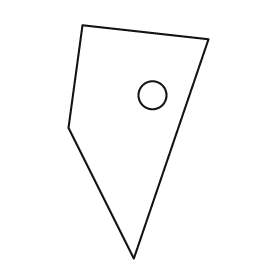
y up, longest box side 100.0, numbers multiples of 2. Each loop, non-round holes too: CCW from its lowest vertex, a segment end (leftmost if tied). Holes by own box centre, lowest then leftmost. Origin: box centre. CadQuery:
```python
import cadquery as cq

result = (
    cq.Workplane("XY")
    .moveTo(-2.0, -50.0)
    .lineTo(30.0, 44.0)
    .lineTo(-24.0, 50.0)
    .lineTo(-30.0, 6.0)
    .close()
    .moveTo(6.0, 20.0)
    .circle(6.0)
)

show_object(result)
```